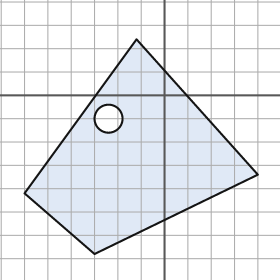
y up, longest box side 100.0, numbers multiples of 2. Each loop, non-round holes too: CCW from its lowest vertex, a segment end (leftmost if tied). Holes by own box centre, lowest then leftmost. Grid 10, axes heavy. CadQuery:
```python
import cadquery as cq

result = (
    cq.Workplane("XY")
    .moveTo(-30.0, -68.0)
    .lineTo(40.0, -34.0)
    .lineTo(-12.0, 24.0)
    .lineTo(-60.0, -42.0)
    .close()
    .moveTo(-24.0, -10.0)
    .circle(6.0)
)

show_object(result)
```